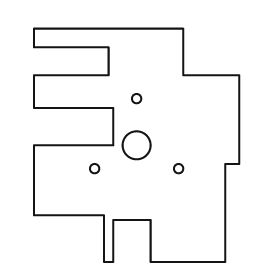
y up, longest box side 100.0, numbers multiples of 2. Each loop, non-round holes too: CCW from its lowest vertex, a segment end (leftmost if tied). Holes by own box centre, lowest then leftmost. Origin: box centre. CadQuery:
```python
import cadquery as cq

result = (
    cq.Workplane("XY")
    .moveTo(-14.0, -50.0)
    .lineTo(-10.0, -50.0)
    .lineTo(-10.0, -32.0)
    .lineTo(6.0, -32.0)
    .lineTo(6.0, -50.0)
    .lineTo(38.0, -50.0)
    .lineTo(38.0, -8.0)
    .lineTo(44.0, -8.0)
    .lineTo(44.0, 30.0)
    .lineTo(20.0, 30.0)
    .lineTo(20.0, 50.0)
    .lineTo(-44.0, 50.0)
    .lineTo(-44.0, 42.0)
    .lineTo(-12.0, 42.0)
    .lineTo(-12.0, 30.0)
    .lineTo(-44.0, 30.0)
    .lineTo(-44.0, 16.0)
    .lineTo(-10.0, 16.0)
    .lineTo(-10.0, 0.0)
    .lineTo(-44.0, 0.0)
    .lineTo(-44.0, -30.0)
    .lineTo(-14.0, -30.0)
    .close()
    .moveTo(-18.0, -10.0)
    .circle(2.0)
    .moveTo(18.0, -10.0)
    .circle(2.0)
    .moveTo(0.0, 0.0)
    .circle(6.0)
    .moveTo(0.0, 20.0)
    .circle(2.0)
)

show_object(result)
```